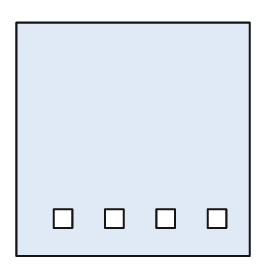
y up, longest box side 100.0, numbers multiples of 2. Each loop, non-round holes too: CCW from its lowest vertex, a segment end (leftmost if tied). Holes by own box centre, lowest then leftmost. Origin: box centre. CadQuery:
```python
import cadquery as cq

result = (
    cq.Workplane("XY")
    .moveTo(-50.0, -50.0)
    .lineTo(50.0, -50.0)
    .lineTo(50.0, 50.0)
    .lineTo(-50.0, 50.0)
    .close()
    .moveTo(-34.0, -38.0)
    .lineTo(-26.0, -38.0)
    .lineTo(-26.0, -30.0)
    .lineTo(-34.0, -30.0)
    .close()
    .moveTo(-12.0, -38.0)
    .lineTo(-4.0, -38.0)
    .lineTo(-4.0, -30.0)
    .lineTo(-12.0, -30.0)
    .close()
    .moveTo(10.0, -38.0)
    .lineTo(18.0, -38.0)
    .lineTo(18.0, -30.0)
    .lineTo(10.0, -30.0)
    .close()
    .moveTo(32.0, -38.0)
    .lineTo(40.0, -38.0)
    .lineTo(40.0, -30.0)
    .lineTo(32.0, -30.0)
    .close()
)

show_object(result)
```